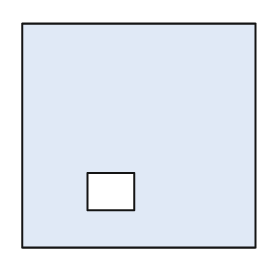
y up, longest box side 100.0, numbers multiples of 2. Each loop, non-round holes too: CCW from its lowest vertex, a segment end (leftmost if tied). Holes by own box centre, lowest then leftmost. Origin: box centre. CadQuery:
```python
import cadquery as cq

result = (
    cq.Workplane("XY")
    .moveTo(-50.0, -48.0)
    .lineTo(50.0, -48.0)
    .lineTo(50.0, 48.0)
    .lineTo(-50.0, 48.0)
    .close()
    .moveTo(-22.0, -32.0)
    .lineTo(-2.0, -32.0)
    .lineTo(-2.0, -16.0)
    .lineTo(-22.0, -16.0)
    .close()
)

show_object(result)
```